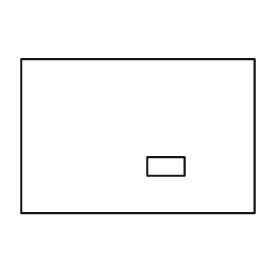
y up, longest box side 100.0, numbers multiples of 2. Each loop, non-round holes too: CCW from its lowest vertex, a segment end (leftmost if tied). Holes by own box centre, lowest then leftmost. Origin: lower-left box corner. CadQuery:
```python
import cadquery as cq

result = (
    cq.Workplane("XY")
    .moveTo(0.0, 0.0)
    .lineTo(100.0, 0.0)
    .lineTo(100.0, 66.0)
    .lineTo(0.0, 66.0)
    .close()
    .moveTo(54.0, 16.0)
    .lineTo(70.0, 16.0)
    .lineTo(70.0, 24.0)
    .lineTo(54.0, 24.0)
    .close()
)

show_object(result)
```